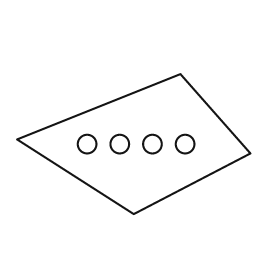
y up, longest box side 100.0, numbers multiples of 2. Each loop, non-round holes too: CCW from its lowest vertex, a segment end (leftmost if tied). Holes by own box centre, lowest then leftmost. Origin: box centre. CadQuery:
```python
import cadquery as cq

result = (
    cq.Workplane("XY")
    .moveTo(0.0, -30.0)
    .lineTo(50.0, -4.0)
    .lineTo(20.0, 30.0)
    .lineTo(-50.0, 2.0)
    .close()
    .moveTo(-20.0, 0.0)
    .circle(4.0)
    .moveTo(-6.0, 0.0)
    .circle(4.0)
    .moveTo(8.0, 0.0)
    .circle(4.0)
    .moveTo(22.0, 0.0)
    .circle(4.0)
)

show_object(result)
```